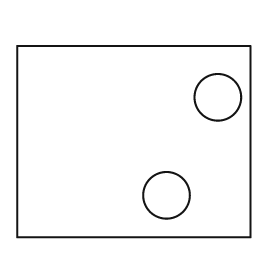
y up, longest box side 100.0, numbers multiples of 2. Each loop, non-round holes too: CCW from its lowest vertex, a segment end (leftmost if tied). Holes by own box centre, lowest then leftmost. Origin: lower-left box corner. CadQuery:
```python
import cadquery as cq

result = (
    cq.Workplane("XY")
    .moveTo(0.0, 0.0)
    .lineTo(100.0, 0.0)
    .lineTo(100.0, 82.0)
    .lineTo(0.0, 82.0)
    .close()
    .moveTo(64.0, 18.0)
    .circle(10.0)
    .moveTo(86.0, 60.0)
    .circle(10.0)
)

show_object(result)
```